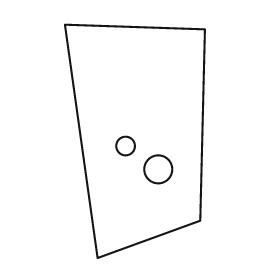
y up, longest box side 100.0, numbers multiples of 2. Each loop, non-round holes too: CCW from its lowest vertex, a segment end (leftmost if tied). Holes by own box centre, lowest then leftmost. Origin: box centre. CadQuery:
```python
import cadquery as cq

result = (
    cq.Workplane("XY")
    .moveTo(-16.0, -50.0)
    .lineTo(28.0, -34.0)
    .lineTo(30.0, 48.0)
    .lineTo(-30.0, 50.0)
    .close()
    .moveTo(10.0, -12.0)
    .circle(6.0)
    .moveTo(-4.0, -2.0)
    .circle(4.0)
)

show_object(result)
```